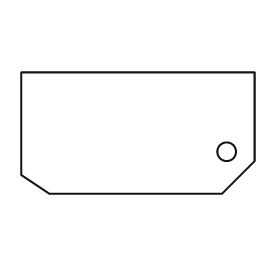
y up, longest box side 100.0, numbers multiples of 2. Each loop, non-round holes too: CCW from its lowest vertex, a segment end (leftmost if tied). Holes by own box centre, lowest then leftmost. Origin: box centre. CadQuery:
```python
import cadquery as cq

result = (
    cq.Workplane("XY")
    .moveTo(-38.0, -26.0)
    .lineTo(36.0, -26.0)
    .lineTo(50.0, -12.0)
    .lineTo(50.0, 26.0)
    .lineTo(-50.0, 26.0)
    .lineTo(-50.0, -18.0)
    .close()
    .moveTo(38.0, -8.0)
    .circle(4.0)
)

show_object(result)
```